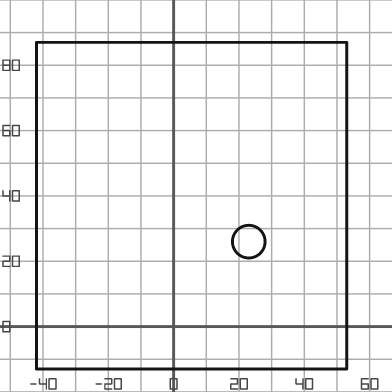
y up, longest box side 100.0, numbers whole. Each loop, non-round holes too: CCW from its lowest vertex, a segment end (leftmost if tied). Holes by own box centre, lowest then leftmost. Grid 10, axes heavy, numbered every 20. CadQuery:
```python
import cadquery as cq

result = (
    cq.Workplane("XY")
    .moveTo(-42.0, -13.0)
    .lineTo(53.0, -13.0)
    .lineTo(53.0, 87.0)
    .lineTo(-42.0, 87.0)
    .close()
    .moveTo(23.0, 26.0)
    .circle(5.0)
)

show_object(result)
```